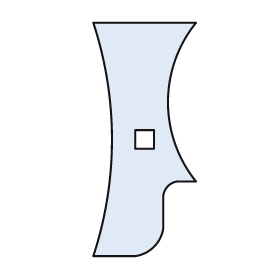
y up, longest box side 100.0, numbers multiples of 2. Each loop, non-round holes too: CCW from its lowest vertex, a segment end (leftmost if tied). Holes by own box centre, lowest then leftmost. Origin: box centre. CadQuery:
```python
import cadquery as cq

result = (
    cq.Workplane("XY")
    .moveTo(-22.0, -50.0)
    .lineTo(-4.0, -50.0)
    .threePointArc((4.0, -46.0), (8.0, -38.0))
    .lineTo(8.0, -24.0)
    .threePointArc((10.0, -20.0), (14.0, -18.0))
    .lineTo(22.0, -18.0)
    .threePointArc((10.0, 16.0), (22.0, 50.0))
    .lineTo(-22.0, 50.0)
    .threePointArc((-14.0, 0.0), (-22.0, -50.0))
    .close()
    .moveTo(-4.0, -4.0)
    .lineTo(4.0, -4.0)
    .lineTo(4.0, 4.0)
    .lineTo(-4.0, 4.0)
    .close()
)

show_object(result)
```